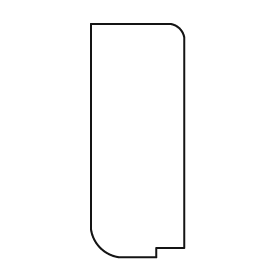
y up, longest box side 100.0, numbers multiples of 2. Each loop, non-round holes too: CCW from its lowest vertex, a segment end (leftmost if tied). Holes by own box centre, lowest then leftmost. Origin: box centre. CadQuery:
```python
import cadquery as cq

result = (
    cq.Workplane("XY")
    .moveTo(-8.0, -50.0)
    .lineTo(8.0, -50.0)
    .lineTo(8.0, -46.0)
    .lineTo(20.0, -46.0)
    .lineTo(20.0, 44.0)
    .threePointArc((18.0, 48.0), (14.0, 50.0))
    .lineTo(-20.0, 50.0)
    .lineTo(-20.0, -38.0)
    .threePointArc((-16.0, -46.0), (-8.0, -50.0))
    .close()
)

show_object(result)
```